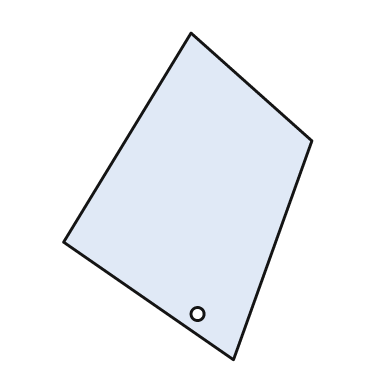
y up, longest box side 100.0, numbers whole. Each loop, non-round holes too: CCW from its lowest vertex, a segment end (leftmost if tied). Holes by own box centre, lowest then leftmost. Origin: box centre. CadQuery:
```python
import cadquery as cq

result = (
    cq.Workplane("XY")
    .moveTo(14.0, -50.0)
    .lineTo(38.0, 17.0)
    .lineTo(1.0, 50.0)
    .lineTo(-38.0, -14.0)
    .close()
    .moveTo(3.0, -36.0)
    .circle(2.0)
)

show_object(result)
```